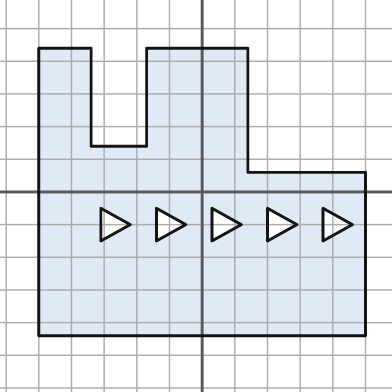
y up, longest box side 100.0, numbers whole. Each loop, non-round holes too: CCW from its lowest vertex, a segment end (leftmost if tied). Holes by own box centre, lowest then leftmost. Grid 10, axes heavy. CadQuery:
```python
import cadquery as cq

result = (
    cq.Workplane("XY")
    .moveTo(-50.0, -44.0)
    .lineTo(50.0, -44.0)
    .lineTo(50.0, 6.0)
    .lineTo(14.0, 6.0)
    .lineTo(14.0, 44.0)
    .lineTo(-17.0, 44.0)
    .lineTo(-17.0, 14.0)
    .lineTo(-34.0, 14.0)
    .lineTo(-34.0, 44.0)
    .lineTo(-50.0, 44.0)
    .close()
    .moveTo(-31.0, -15.0)
    .lineTo(-22.0, -10.0)
    .lineTo(-31.0, -5.0)
    .close()
    .moveTo(-14.0, -15.0)
    .lineTo(-5.0, -10.0)
    .lineTo(-14.0, -5.0)
    .close()
    .moveTo(3.0, -15.0)
    .lineTo(12.0, -10.0)
    .lineTo(3.0, -5.0)
    .close()
    .moveTo(20.0, -15.0)
    .lineTo(29.0, -10.0)
    .lineTo(20.0, -5.0)
    .close()
    .moveTo(37.0, -15.0)
    .lineTo(46.0, -10.0)
    .lineTo(37.0, -5.0)
    .close()
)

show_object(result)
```